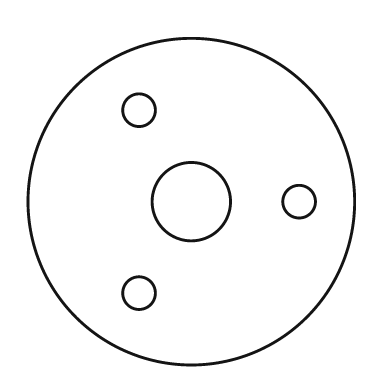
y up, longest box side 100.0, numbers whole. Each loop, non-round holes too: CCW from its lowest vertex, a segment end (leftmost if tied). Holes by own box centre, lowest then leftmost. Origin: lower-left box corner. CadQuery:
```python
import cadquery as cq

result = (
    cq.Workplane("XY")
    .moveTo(50.0, 50.0)
    .circle(50.0)
    .moveTo(34.0, 22.0)
    .circle(5.0)
    .moveTo(50.0, 50.0)
    .circle(12.0)
    .moveTo(83.0, 50.0)
    .circle(5.0)
    .moveTo(34.0, 78.0)
    .circle(5.0)
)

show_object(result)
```